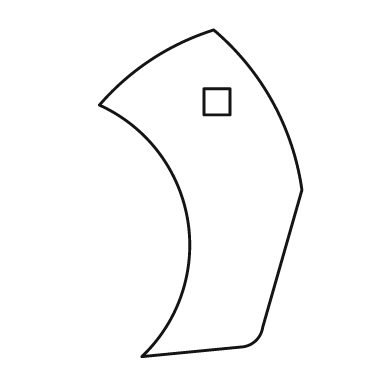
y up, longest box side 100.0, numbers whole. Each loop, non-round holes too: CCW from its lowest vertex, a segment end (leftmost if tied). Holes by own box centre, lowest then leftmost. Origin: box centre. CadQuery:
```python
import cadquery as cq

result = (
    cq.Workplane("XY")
    .moveTo(-18.0, -50.0)
    .lineTo(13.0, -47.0)
    .threePointArc((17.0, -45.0), (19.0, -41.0))
    .lineTo(31.0, 1.0)
    .threePointArc((22.0, 28.0), (4.0, 50.0))
    .threePointArc((-15.0, 41.0), (-31.0, 27.0))
    .threePointArc((-4.0, -8.0), (-18.0, -50.0))
    .close()
    .moveTo(1.0, 24.0)
    .lineTo(9.0, 24.0)
    .lineTo(9.0, 32.0)
    .lineTo(1.0, 32.0)
    .close()
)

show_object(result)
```